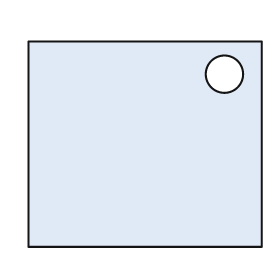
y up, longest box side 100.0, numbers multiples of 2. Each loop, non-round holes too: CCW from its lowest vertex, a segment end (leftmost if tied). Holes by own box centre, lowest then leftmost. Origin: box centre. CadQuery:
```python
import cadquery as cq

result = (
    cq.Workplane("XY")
    .moveTo(-50.0, -44.0)
    .lineTo(50.0, -44.0)
    .lineTo(50.0, 44.0)
    .lineTo(-50.0, 44.0)
    .close()
    .moveTo(34.0, 30.0)
    .circle(8.0)
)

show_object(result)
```